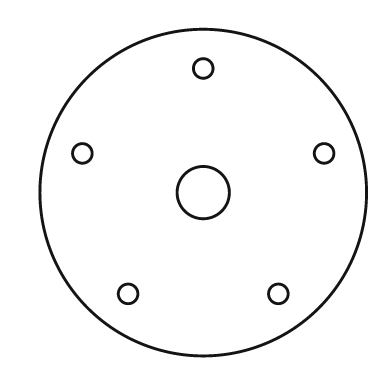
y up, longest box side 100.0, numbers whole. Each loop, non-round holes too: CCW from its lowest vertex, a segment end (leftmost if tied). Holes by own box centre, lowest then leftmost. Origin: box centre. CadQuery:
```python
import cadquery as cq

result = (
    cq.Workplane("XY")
    .moveTo(0.0, 0.0)
    .circle(50.0)
    .moveTo(-23.0, -31.0)
    .circle(3.0)
    .moveTo(23.0, -31.0)
    .circle(3.0)
    .moveTo(0.0, 0.0)
    .circle(8.0)
    .moveTo(-37.0, 12.0)
    .circle(3.0)
    .moveTo(37.0, 12.0)
    .circle(3.0)
    .moveTo(0.0, 38.0)
    .circle(3.0)
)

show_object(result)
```